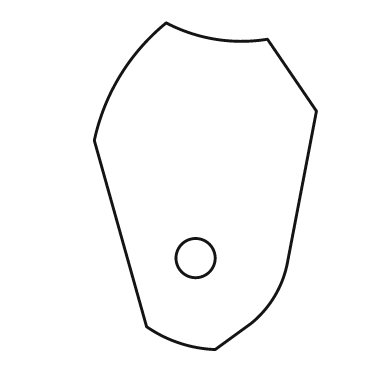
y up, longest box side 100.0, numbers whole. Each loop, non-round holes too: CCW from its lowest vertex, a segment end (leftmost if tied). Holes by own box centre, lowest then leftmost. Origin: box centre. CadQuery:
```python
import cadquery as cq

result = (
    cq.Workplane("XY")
    .moveTo(3.0, -50.0)
    .lineTo(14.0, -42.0)
    .threePointArc((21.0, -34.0), (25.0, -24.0))
    .lineTo(34.0, 23.0)
    .lineTo(19.0, 45.0)
    .threePointArc((3.0, 45.0), (-12.0, 50.0))
    .threePointArc((-26.0, 34.0), (-34.0, 14.0))
    .lineTo(-18.0, -43.0)
    .threePointArc((-8.0, -48.0), (3.0, -50.0))
    .close()
    .moveTo(-3.0, -22.0)
    .circle(6.0)
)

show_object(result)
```